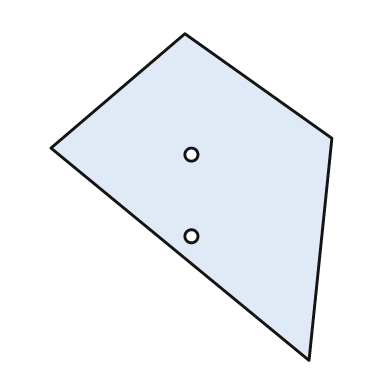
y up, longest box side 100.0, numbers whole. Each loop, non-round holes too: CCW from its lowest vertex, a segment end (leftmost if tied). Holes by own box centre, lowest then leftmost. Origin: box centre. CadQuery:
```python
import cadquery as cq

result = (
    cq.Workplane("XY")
    .moveTo(36.0, -50.0)
    .lineTo(43.0, 18.0)
    .lineTo(-2.0, 50.0)
    .lineTo(-43.0, 15.0)
    .close()
    .moveTo(0.0, -12.0)
    .circle(2.0)
    .moveTo(0.0, 13.0)
    .circle(2.0)
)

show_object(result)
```